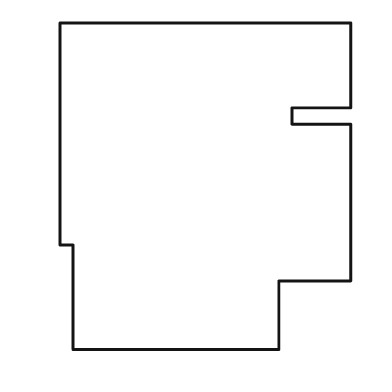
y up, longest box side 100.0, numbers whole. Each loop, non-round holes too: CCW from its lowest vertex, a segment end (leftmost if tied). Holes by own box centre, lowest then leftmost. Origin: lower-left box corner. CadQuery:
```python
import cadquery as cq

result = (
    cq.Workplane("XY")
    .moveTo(4.0, 0.0)
    .lineTo(67.0, 0.0)
    .lineTo(67.0, 21.0)
    .lineTo(89.0, 21.0)
    .lineTo(89.0, 69.0)
    .lineTo(71.0, 69.0)
    .lineTo(71.0, 74.0)
    .lineTo(89.0, 74.0)
    .lineTo(89.0, 100.0)
    .lineTo(0.0, 100.0)
    .lineTo(0.0, 32.0)
    .lineTo(4.0, 32.0)
    .close()
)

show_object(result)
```